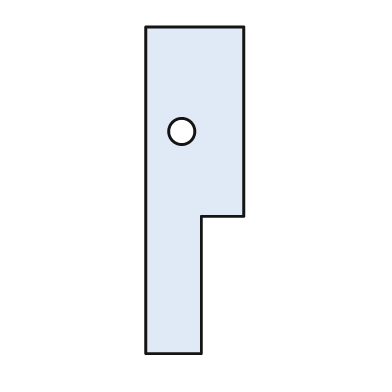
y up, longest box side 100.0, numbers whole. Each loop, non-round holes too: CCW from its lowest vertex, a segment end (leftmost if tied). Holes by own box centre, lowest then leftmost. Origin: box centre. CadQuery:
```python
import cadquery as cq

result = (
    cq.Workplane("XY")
    .moveTo(-15.0, -50.0)
    .lineTo(2.0, -50.0)
    .lineTo(2.0, -8.0)
    .lineTo(15.0, -8.0)
    .lineTo(15.0, 50.0)
    .lineTo(-15.0, 50.0)
    .close()
    .moveTo(-4.0, 18.0)
    .circle(4.0)
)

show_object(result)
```